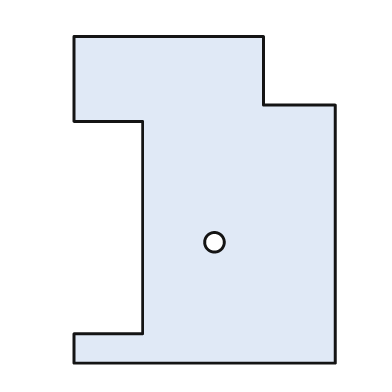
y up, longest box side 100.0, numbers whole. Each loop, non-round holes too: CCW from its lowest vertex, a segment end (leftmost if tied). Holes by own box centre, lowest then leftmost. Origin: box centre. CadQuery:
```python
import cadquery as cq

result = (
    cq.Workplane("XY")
    .moveTo(-40.0, -50.0)
    .lineTo(40.0, -50.0)
    .lineTo(40.0, 29.0)
    .lineTo(18.0, 29.0)
    .lineTo(18.0, 50.0)
    .lineTo(-40.0, 50.0)
    .lineTo(-40.0, 24.0)
    .lineTo(-19.0, 24.0)
    .lineTo(-19.0, -41.0)
    .lineTo(-40.0, -41.0)
    .close()
    .moveTo(3.0, -13.0)
    .circle(3.0)
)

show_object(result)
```